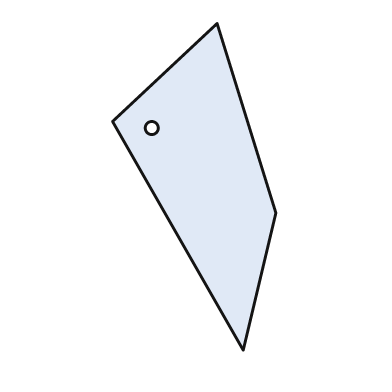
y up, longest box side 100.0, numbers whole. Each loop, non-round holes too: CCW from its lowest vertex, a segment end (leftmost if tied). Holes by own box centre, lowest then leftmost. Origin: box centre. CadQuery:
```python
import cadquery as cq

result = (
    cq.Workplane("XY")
    .moveTo(15.0, -50.0)
    .lineTo(25.0, -8.0)
    .lineTo(7.0, 50.0)
    .lineTo(-25.0, 20.0)
    .close()
    .moveTo(-13.0, 18.0)
    .circle(2.0)
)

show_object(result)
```